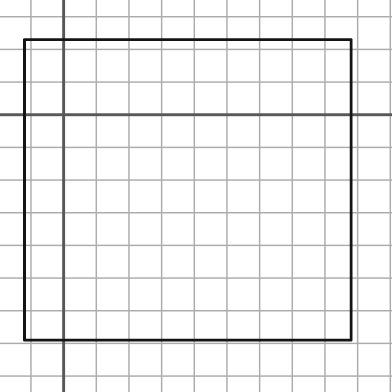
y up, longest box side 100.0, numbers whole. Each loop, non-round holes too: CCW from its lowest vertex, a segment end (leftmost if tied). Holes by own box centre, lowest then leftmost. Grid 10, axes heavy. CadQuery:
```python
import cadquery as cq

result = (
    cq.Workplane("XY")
    .moveTo(-12.0, -69.0)
    .lineTo(88.0, -69.0)
    .lineTo(88.0, 23.0)
    .lineTo(-12.0, 23.0)
    .close()
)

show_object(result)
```